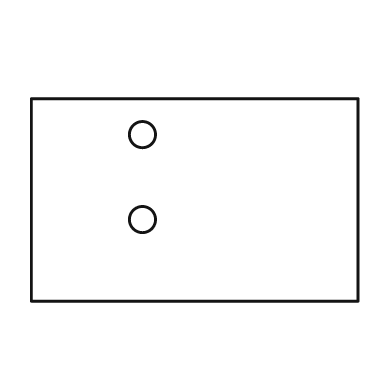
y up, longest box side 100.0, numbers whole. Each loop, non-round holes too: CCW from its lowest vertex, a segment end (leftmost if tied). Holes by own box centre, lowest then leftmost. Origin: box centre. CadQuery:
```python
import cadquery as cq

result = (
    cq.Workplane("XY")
    .moveTo(-50.0, -31.0)
    .lineTo(50.0, -31.0)
    .lineTo(50.0, 31.0)
    .lineTo(-50.0, 31.0)
    .close()
    .moveTo(-16.0, -6.0)
    .circle(4.0)
    .moveTo(-16.0, 20.0)
    .circle(4.0)
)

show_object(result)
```